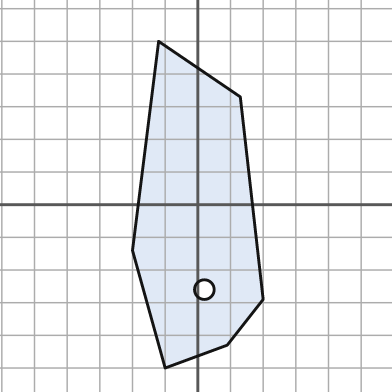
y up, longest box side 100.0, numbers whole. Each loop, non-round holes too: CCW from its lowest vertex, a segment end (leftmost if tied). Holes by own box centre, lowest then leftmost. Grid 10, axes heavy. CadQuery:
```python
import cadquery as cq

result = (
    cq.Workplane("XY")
    .moveTo(-10.0, -50.0)
    .lineTo(9.0, -43.0)
    .lineTo(20.0, -29.0)
    .lineTo(13.0, 33.0)
    .lineTo(-12.0, 50.0)
    .lineTo(-20.0, -14.0)
    .close()
    .moveTo(2.0, -26.0)
    .circle(3.0)
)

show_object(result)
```